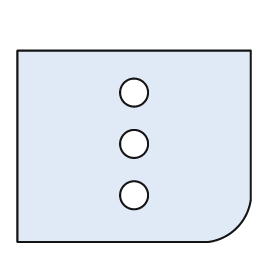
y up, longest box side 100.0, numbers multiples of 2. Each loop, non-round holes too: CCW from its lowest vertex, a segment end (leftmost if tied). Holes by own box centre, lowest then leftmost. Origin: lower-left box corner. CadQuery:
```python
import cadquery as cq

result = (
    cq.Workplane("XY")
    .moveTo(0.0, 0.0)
    .lineTo(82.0, 0.0)
    .threePointArc((94.0, 6.0), (100.0, 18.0))
    .lineTo(100.0, 82.0)
    .lineTo(0.0, 82.0)
    .close()
    .moveTo(50.0, 20.0)
    .circle(6.0)
    .moveTo(50.0, 42.0)
    .circle(6.0)
    .moveTo(50.0, 64.0)
    .circle(6.0)
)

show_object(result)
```